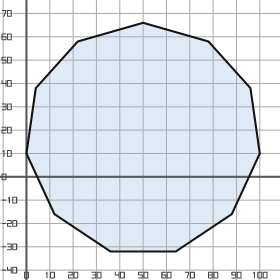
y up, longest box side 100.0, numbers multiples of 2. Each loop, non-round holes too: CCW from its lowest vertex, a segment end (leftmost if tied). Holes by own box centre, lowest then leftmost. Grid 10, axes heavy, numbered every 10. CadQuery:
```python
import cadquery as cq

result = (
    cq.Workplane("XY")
    .moveTo(36.0, -32.0)
    .lineTo(64.0, -32.0)
    .lineTo(88.0, -16.0)
    .lineTo(100.0, 10.0)
    .lineTo(96.0, 38.0)
    .lineTo(78.0, 58.0)
    .lineTo(50.0, 66.0)
    .lineTo(22.0, 58.0)
    .lineTo(4.0, 38.0)
    .lineTo(0.0, 10.0)
    .lineTo(12.0, -16.0)
    .close()
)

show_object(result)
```